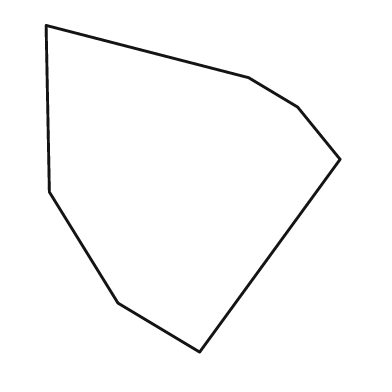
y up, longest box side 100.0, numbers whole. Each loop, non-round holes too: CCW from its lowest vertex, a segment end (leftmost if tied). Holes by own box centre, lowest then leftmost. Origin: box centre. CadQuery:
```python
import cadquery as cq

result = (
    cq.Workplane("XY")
    .moveTo(2.0, -50.0)
    .lineTo(45.0, 9.0)
    .lineTo(32.0, 25.0)
    .lineTo(17.0, 34.0)
    .lineTo(-45.0, 50.0)
    .lineTo(-44.0, -1.0)
    .lineTo(-23.0, -35.0)
    .close()
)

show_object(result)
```